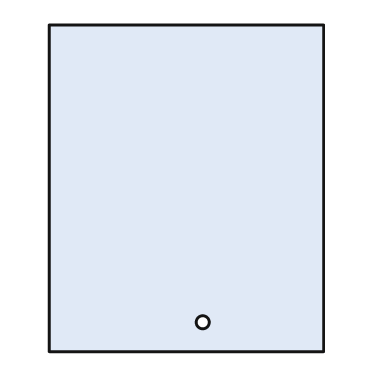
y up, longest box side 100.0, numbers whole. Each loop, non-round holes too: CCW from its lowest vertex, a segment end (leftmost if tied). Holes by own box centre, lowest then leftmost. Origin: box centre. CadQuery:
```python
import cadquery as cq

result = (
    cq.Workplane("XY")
    .moveTo(-42.0, -50.0)
    .lineTo(42.0, -50.0)
    .lineTo(42.0, 50.0)
    .lineTo(-42.0, 50.0)
    .close()
    .moveTo(5.0, -41.0)
    .circle(2.0)
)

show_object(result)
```